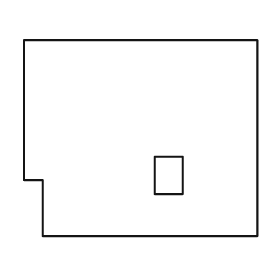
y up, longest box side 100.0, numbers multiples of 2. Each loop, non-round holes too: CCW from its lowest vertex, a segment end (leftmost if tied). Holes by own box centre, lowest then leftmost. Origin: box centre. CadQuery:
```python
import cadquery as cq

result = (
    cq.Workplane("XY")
    .moveTo(-42.0, -42.0)
    .lineTo(50.0, -42.0)
    .lineTo(50.0, 42.0)
    .lineTo(-50.0, 42.0)
    .lineTo(-50.0, -18.0)
    .lineTo(-42.0, -18.0)
    .close()
    .moveTo(6.0, -24.0)
    .lineTo(18.0, -24.0)
    .lineTo(18.0, -8.0)
    .lineTo(6.0, -8.0)
    .close()
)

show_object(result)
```